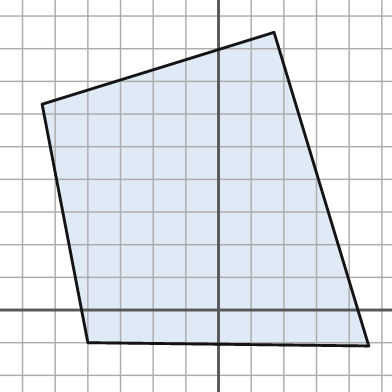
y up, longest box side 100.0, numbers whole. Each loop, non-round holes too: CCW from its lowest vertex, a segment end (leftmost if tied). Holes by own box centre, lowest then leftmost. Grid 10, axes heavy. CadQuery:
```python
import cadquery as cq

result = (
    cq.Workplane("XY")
    .moveTo(46.0, -11.0)
    .lineTo(17.0, 85.0)
    .lineTo(-54.0, 63.0)
    .lineTo(-40.0, -10.0)
    .close()
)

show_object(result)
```